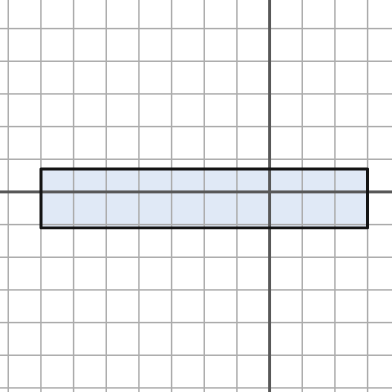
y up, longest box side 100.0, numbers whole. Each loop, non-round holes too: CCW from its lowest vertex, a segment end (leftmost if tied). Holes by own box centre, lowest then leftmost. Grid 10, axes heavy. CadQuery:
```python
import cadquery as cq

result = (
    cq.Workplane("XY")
    .moveTo(-70.0, -11.0)
    .lineTo(30.0, -11.0)
    .lineTo(30.0, 7.0)
    .lineTo(-70.0, 7.0)
    .close()
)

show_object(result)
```